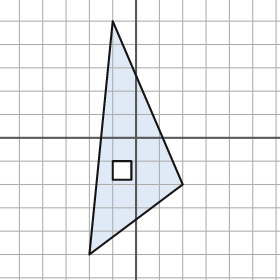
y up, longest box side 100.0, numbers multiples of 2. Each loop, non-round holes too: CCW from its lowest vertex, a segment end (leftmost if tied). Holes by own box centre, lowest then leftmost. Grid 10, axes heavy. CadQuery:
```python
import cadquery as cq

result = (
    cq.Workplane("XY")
    .moveTo(-20.0, -50.0)
    .lineTo(20.0, -20.0)
    .lineTo(-10.0, 50.0)
    .close()
    .moveTo(-10.0, -18.0)
    .lineTo(-2.0, -18.0)
    .lineTo(-2.0, -10.0)
    .lineTo(-10.0, -10.0)
    .close()
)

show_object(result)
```